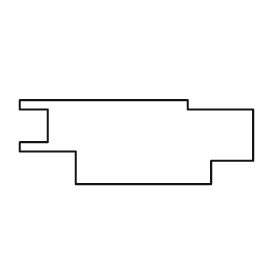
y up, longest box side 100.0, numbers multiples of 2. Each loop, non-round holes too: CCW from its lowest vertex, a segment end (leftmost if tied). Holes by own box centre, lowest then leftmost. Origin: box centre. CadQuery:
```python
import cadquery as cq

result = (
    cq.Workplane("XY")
    .moveTo(-26.0, -18.0)
    .lineTo(32.0, -18.0)
    .lineTo(32.0, -8.0)
    .lineTo(50.0, -8.0)
    .lineTo(50.0, 14.0)
    .lineTo(22.0, 14.0)
    .lineTo(22.0, 18.0)
    .lineTo(-50.0, 18.0)
    .lineTo(-50.0, 14.0)
    .lineTo(-38.0, 14.0)
    .lineTo(-38.0, 0.0)
    .lineTo(-50.0, 0.0)
    .lineTo(-50.0, -4.0)
    .lineTo(-26.0, -4.0)
    .close()
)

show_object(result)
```